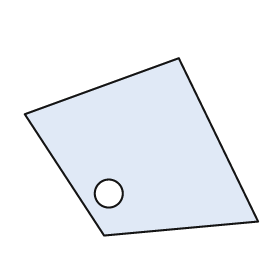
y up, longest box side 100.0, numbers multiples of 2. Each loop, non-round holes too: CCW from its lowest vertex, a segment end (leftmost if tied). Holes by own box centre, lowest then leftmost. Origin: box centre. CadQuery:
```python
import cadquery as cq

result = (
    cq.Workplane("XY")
    .moveTo(-16.0, -38.0)
    .lineTo(50.0, -32.0)
    .lineTo(16.0, 38.0)
    .lineTo(-50.0, 14.0)
    .close()
    .moveTo(-14.0, -20.0)
    .circle(6.0)
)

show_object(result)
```